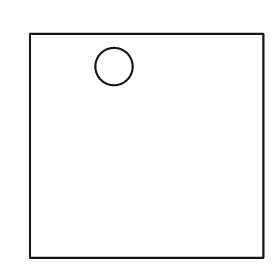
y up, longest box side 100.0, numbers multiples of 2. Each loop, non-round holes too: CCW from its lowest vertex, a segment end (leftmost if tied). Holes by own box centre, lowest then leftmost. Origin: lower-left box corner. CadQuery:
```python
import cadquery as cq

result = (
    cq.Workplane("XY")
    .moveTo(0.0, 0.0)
    .lineTo(100.0, 0.0)
    .lineTo(100.0, 96.0)
    .lineTo(0.0, 96.0)
    .close()
    .moveTo(36.0, 82.0)
    .circle(8.0)
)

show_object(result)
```